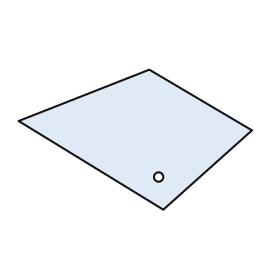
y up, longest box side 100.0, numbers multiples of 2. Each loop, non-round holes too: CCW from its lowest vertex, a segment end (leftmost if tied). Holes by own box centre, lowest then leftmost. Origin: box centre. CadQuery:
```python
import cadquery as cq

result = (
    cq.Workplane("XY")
    .moveTo(12.0, -30.0)
    .lineTo(50.0, 4.0)
    .lineTo(6.0, 30.0)
    .lineTo(-50.0, 8.0)
    .close()
    .moveTo(10.0, -16.0)
    .circle(2.0)
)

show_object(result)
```